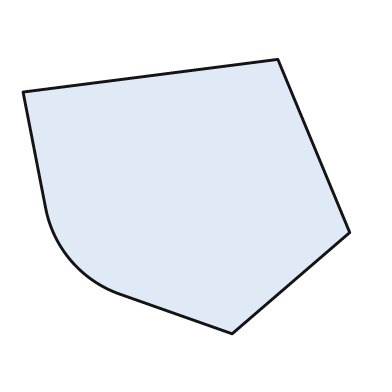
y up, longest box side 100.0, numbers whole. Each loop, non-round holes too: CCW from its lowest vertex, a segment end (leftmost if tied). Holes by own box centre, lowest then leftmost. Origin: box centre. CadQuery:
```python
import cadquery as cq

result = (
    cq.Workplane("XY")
    .moveTo(14.0, -42.0)
    .lineTo(50.0, -11.0)
    .lineTo(28.0, 42.0)
    .lineTo(-50.0, 32.0)
    .lineTo(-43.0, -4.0)
    .threePointArc((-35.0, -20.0), (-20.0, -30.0))
    .close()
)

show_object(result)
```